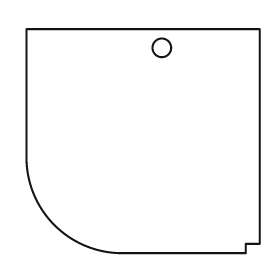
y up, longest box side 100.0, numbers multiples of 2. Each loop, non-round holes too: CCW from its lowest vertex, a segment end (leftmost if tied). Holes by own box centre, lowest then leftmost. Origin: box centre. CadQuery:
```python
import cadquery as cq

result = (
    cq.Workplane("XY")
    .moveTo(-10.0, -48.0)
    .lineTo(44.0, -48.0)
    .lineTo(44.0, -44.0)
    .lineTo(50.0, -44.0)
    .lineTo(50.0, 48.0)
    .lineTo(-50.0, 48.0)
    .lineTo(-50.0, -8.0)
    .threePointArc((-38.0, -36.0), (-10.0, -48.0))
    .close()
    .moveTo(8.0, 40.0)
    .circle(4.0)
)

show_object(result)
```